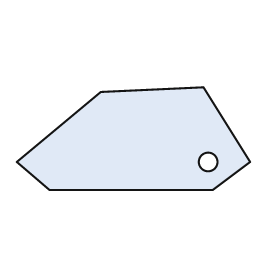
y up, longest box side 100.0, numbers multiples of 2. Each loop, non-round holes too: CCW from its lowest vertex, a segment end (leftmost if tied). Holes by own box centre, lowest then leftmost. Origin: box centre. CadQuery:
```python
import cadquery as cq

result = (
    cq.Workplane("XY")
    .moveTo(-36.0, -22.0)
    .lineTo(34.0, -22.0)
    .lineTo(50.0, -10.0)
    .lineTo(30.0, 22.0)
    .lineTo(-14.0, 20.0)
    .lineTo(-50.0, -10.0)
    .close()
    .moveTo(32.0, -10.0)
    .circle(4.0)
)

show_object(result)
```